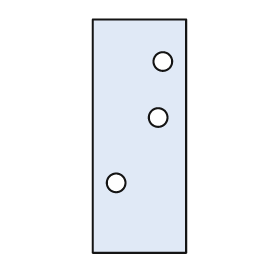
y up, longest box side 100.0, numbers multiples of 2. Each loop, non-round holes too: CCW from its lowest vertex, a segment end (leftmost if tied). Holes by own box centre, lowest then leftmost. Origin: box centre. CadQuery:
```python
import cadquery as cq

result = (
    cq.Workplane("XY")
    .moveTo(-20.0, -50.0)
    .lineTo(20.0, -50.0)
    .lineTo(20.0, 50.0)
    .lineTo(-20.0, 50.0)
    .close()
    .moveTo(-10.0, -20.0)
    .circle(4.0)
    .moveTo(8.0, 8.0)
    .circle(4.0)
    .moveTo(10.0, 32.0)
    .circle(4.0)
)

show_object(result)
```